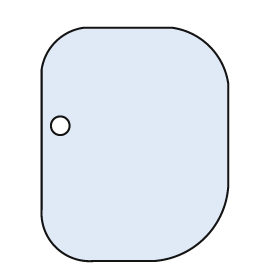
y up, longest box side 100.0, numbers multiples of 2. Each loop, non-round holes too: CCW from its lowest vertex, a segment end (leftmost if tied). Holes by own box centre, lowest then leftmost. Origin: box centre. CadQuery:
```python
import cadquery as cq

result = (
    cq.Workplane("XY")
    .moveTo(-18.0, -50.0)
    .lineTo(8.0, -50.0)
    .threePointArc((30.0, -40.0), (40.0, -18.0))
    .lineTo(40.0, 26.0)
    .threePointArc((32.0, 42.0), (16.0, 50.0))
    .lineTo(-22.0, 50.0)
    .threePointArc((-34.0, 44.0), (-40.0, 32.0))
    .lineTo(-40.0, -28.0)
    .threePointArc((-34.0, -44.0), (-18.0, -50.0))
    .close()
    .moveTo(-32.0, 8.0)
    .circle(4.0)
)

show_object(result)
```